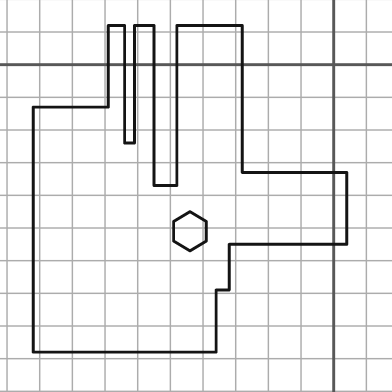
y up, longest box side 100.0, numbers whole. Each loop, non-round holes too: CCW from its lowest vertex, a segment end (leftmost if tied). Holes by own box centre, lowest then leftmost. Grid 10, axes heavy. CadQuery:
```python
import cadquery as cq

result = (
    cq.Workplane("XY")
    .moveTo(-92.0, -88.0)
    .lineTo(-36.0, -88.0)
    .lineTo(-36.0, -69.0)
    .lineTo(-32.0, -69.0)
    .lineTo(-32.0, -55.0)
    .lineTo(4.0, -55.0)
    .lineTo(4.0, -33.0)
    .lineTo(-28.0, -33.0)
    .lineTo(-28.0, 12.0)
    .lineTo(-48.0, 12.0)
    .lineTo(-48.0, -37.0)
    .lineTo(-55.0, -37.0)
    .lineTo(-55.0, 12.0)
    .lineTo(-61.0, 12.0)
    .lineTo(-61.0, -24.0)
    .lineTo(-64.0, -24.0)
    .lineTo(-64.0, 12.0)
    .lineTo(-69.0, 12.0)
    .lineTo(-69.0, -13.0)
    .lineTo(-92.0, -13.0)
    .close()
    .moveTo(-44.0, -57.0)
    .lineTo(-39.0, -54.0)
    .lineTo(-39.0, -48.0)
    .lineTo(-44.0, -45.0)
    .lineTo(-49.0, -48.0)
    .lineTo(-49.0, -54.0)
    .close()
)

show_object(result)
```